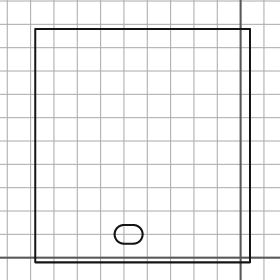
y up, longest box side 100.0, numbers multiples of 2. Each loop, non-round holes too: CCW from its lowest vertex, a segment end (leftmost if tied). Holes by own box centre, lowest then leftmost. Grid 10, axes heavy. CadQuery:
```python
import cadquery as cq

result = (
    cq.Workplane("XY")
    .moveTo(-88.0, -2.0)
    .lineTo(4.0, -2.0)
    .lineTo(4.0, 98.0)
    .lineTo(-88.0, 98.0)
    .close()
    .moveTo(-50.0, 6.0)
    .lineTo(-46.0, 6.0)
    .threePointArc((-42.0, 10.0), (-46.0, 14.0))
    .lineTo(-50.0, 14.0)
    .threePointArc((-54.0, 10.0), (-50.0, 6.0))
    .close()
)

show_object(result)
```